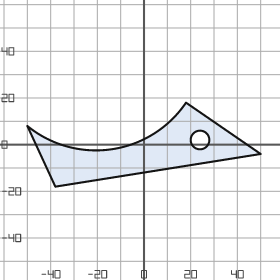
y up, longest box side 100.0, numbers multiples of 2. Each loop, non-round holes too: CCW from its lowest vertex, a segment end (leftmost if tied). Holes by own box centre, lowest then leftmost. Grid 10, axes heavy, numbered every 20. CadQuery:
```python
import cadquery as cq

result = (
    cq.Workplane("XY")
    .moveTo(-38.0, -18.0)
    .lineTo(50.0, -4.0)
    .lineTo(18.0, 18.0)
    .threePointArc((-14.0, -2.0), (-50.0, 8.0))
    .close()
    .moveTo(24.0, 2.0)
    .circle(4.0)
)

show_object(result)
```